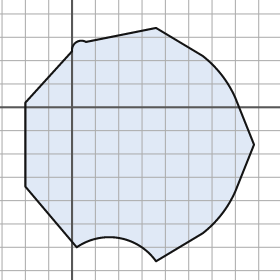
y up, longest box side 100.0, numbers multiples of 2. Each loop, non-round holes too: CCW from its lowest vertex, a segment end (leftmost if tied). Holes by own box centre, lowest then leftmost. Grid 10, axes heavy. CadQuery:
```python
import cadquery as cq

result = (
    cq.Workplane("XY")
    .moveTo(36.0, -66.0)
    .lineTo(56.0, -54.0)
    .threePointArc((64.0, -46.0), (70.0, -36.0))
    .lineTo(78.0, -16.0)
    .lineTo(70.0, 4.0)
    .threePointArc((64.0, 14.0), (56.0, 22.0))
    .lineTo(36.0, 34.0)
    .lineTo(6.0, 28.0)
    .threePointArc((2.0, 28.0), (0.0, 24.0))
    .lineTo(-20.0, 2.0)
    .lineTo(-20.0, -34.0)
    .lineTo(2.0, -60.0)
    .threePointArc((20.0, -56.0), (36.0, -66.0))
    .close()
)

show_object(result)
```